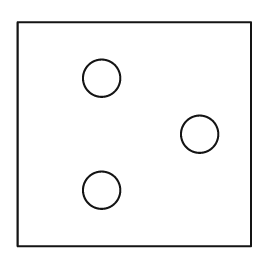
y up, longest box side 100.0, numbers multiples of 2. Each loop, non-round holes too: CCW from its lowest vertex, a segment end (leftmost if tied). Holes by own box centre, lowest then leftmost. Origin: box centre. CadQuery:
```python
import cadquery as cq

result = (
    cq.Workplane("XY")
    .moveTo(-50.0, -48.0)
    .lineTo(50.0, -48.0)
    .lineTo(50.0, 48.0)
    .lineTo(-50.0, 48.0)
    .close()
    .moveTo(-14.0, -24.0)
    .circle(8.0)
    .moveTo(28.0, 0.0)
    .circle(8.0)
    .moveTo(-14.0, 24.0)
    .circle(8.0)
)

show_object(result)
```